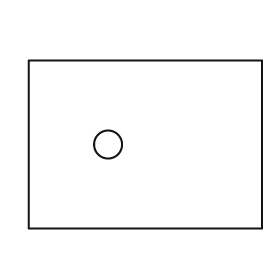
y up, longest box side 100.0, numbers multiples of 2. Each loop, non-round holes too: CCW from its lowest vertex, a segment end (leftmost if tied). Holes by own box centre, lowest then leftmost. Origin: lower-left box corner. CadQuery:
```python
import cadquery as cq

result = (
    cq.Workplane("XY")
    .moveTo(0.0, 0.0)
    .lineTo(100.0, 0.0)
    .lineTo(100.0, 72.0)
    .lineTo(0.0, 72.0)
    .close()
    .moveTo(34.0, 36.0)
    .circle(6.0)
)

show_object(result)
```